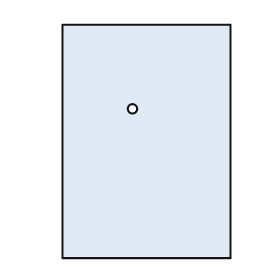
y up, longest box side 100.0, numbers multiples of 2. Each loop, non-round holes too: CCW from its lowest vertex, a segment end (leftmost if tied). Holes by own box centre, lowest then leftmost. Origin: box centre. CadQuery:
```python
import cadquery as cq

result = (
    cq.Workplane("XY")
    .moveTo(-36.0, -50.0)
    .lineTo(36.0, -50.0)
    .lineTo(36.0, 50.0)
    .lineTo(-36.0, 50.0)
    .close()
    .moveTo(-6.0, 14.0)
    .circle(2.0)
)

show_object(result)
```